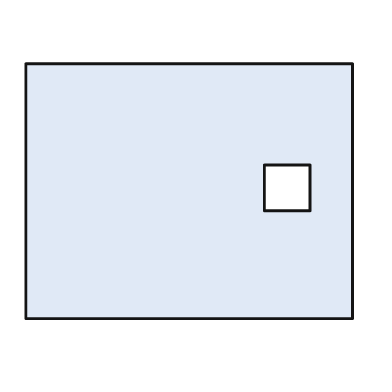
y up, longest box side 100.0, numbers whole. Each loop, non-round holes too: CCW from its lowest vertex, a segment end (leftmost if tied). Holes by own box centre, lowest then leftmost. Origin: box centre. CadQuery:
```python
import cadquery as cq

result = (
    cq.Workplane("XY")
    .moveTo(-50.0, -39.0)
    .lineTo(50.0, -39.0)
    .lineTo(50.0, 39.0)
    .lineTo(-50.0, 39.0)
    .close()
    .moveTo(23.0, -6.0)
    .lineTo(37.0, -6.0)
    .lineTo(37.0, 8.0)
    .lineTo(23.0, 8.0)
    .close()
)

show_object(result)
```